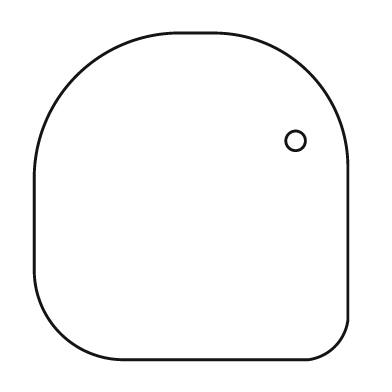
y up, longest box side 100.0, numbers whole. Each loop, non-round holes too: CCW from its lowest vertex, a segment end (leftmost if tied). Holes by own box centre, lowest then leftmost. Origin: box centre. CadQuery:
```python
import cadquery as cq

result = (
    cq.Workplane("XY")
    .moveTo(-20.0, -50.0)
    .lineTo(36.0, -50.0)
    .threePointArc((44.0, -46.0), (48.0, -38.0))
    .lineTo(48.0, 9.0)
    .threePointArc((36.0, 38.0), (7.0, 50.0))
    .lineTo(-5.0, 50.0)
    .threePointArc((-35.0, 37.0), (-48.0, 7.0))
    .lineTo(-48.0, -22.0)
    .threePointArc((-40.0, -42.0), (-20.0, -50.0))
    .close()
    .moveTo(32.0, 17.0)
    .circle(3.0)
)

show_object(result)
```